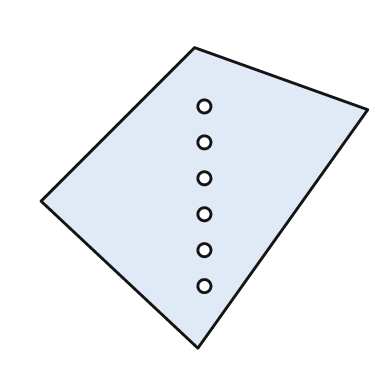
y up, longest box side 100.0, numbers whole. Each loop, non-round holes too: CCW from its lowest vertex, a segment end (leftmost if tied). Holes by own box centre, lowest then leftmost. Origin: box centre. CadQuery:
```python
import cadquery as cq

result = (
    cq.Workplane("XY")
    .moveTo(-2.0, -46.0)
    .lineTo(50.0, 27.0)
    .lineTo(-3.0, 46.0)
    .lineTo(-50.0, -1.0)
    .close()
    .moveTo(0.0, -27.0)
    .circle(2.0)
    .moveTo(0.0, -16.0)
    .circle(2.0)
    .moveTo(0.0, -5.0)
    .circle(2.0)
    .moveTo(0.0, 6.0)
    .circle(2.0)
    .moveTo(0.0, 17.0)
    .circle(2.0)
    .moveTo(0.0, 28.0)
    .circle(2.0)
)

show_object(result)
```